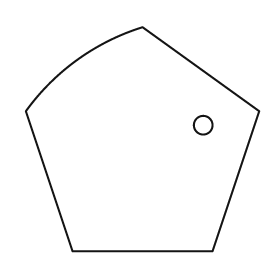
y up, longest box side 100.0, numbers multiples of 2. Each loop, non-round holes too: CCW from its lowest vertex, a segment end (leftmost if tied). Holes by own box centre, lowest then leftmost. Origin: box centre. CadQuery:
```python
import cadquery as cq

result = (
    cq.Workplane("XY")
    .moveTo(-30.0, -48.0)
    .lineTo(30.0, -48.0)
    .lineTo(50.0, 12.0)
    .lineTo(0.0, 48.0)
    .threePointArc((-28.0, 34.0), (-50.0, 12.0))
    .close()
    .moveTo(26.0, 6.0)
    .circle(4.0)
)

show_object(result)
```